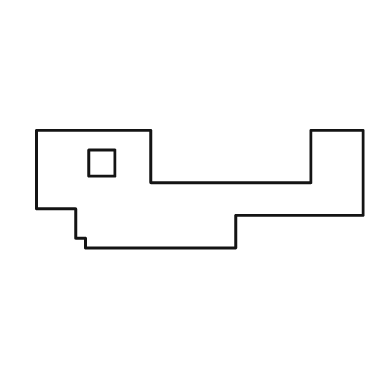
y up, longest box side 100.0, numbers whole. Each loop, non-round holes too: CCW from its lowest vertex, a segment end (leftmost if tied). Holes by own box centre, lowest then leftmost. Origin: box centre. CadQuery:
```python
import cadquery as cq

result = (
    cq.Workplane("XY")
    .moveTo(-35.0, -18.0)
    .lineTo(11.0, -18.0)
    .lineTo(11.0, -8.0)
    .lineTo(50.0, -8.0)
    .lineTo(50.0, 18.0)
    .lineTo(34.0, 18.0)
    .lineTo(34.0, 2.0)
    .lineTo(-15.0, 2.0)
    .lineTo(-15.0, 18.0)
    .lineTo(-50.0, 18.0)
    .lineTo(-50.0, -6.0)
    .lineTo(-38.0, -6.0)
    .lineTo(-38.0, -15.0)
    .lineTo(-35.0, -15.0)
    .close()
    .moveTo(-34.0, 4.0)
    .lineTo(-26.0, 4.0)
    .lineTo(-26.0, 12.0)
    .lineTo(-34.0, 12.0)
    .close()
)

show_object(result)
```